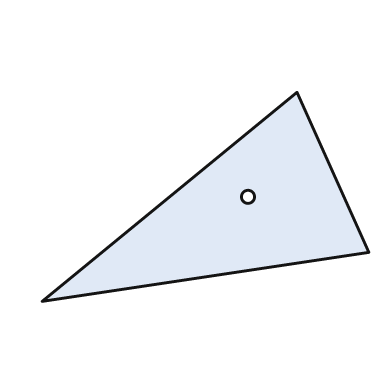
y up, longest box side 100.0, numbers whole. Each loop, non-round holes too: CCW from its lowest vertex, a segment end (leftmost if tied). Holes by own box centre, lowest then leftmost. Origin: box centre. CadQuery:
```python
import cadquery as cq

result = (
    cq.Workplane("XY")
    .moveTo(-50.0, -32.0)
    .lineTo(50.0, -17.0)
    .lineTo(28.0, 32.0)
    .close()
    .moveTo(13.0, 0.0)
    .circle(2.0)
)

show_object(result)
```